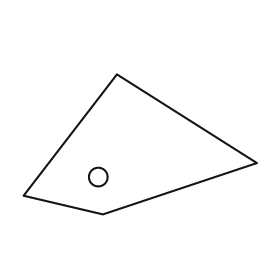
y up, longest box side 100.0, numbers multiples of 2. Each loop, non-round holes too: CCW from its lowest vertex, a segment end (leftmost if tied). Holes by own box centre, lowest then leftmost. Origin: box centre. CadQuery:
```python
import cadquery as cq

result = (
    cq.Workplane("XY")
    .moveTo(-16.0, -30.0)
    .lineTo(50.0, -8.0)
    .lineTo(-10.0, 30.0)
    .lineTo(-50.0, -22.0)
    .close()
    .moveTo(-18.0, -14.0)
    .circle(4.0)
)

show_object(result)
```